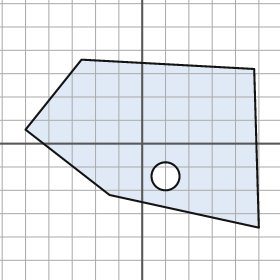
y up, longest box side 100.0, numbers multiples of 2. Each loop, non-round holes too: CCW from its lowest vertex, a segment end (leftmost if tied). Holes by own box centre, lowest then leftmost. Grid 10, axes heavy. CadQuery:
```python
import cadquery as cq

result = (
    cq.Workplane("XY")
    .moveTo(50.0, -36.0)
    .lineTo(48.0, 32.0)
    .lineTo(-26.0, 36.0)
    .lineTo(-50.0, 6.0)
    .lineTo(-14.0, -22.0)
    .close()
    .moveTo(10.0, -14.0)
    .circle(6.0)
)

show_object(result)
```